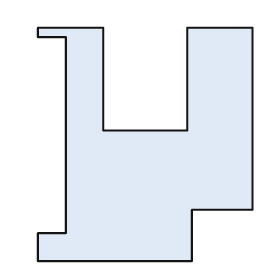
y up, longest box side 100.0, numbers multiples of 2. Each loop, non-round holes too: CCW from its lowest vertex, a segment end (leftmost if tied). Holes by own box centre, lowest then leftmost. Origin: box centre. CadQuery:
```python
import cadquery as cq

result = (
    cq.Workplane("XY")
    .moveTo(-46.0, -50.0)
    .lineTo(20.0, -50.0)
    .lineTo(20.0, -28.0)
    .lineTo(46.0, -28.0)
    .lineTo(46.0, 50.0)
    .lineTo(18.0, 50.0)
    .lineTo(18.0, 6.0)
    .lineTo(-18.0, 6.0)
    .lineTo(-18.0, 50.0)
    .lineTo(-46.0, 50.0)
    .lineTo(-46.0, 46.0)
    .lineTo(-34.0, 46.0)
    .lineTo(-34.0, -38.0)
    .lineTo(-46.0, -38.0)
    .close()
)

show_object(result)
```